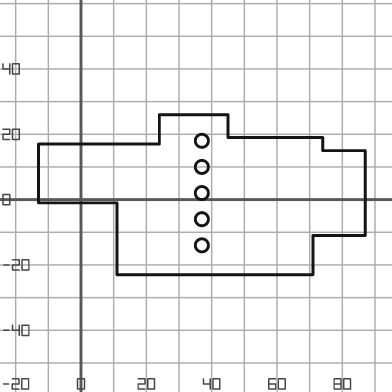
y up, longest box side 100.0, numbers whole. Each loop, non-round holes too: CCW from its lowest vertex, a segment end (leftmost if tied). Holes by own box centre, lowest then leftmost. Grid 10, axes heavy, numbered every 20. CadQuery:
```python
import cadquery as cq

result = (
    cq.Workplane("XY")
    .moveTo(11.0, -23.0)
    .lineTo(71.0, -23.0)
    .lineTo(71.0, -11.0)
    .lineTo(87.0, -11.0)
    .lineTo(87.0, 15.0)
    .lineTo(74.0, 15.0)
    .lineTo(74.0, 19.0)
    .lineTo(45.0, 19.0)
    .lineTo(45.0, 26.0)
    .lineTo(24.0, 26.0)
    .lineTo(24.0, 17.0)
    .lineTo(-13.0, 17.0)
    .lineTo(-13.0, -1.0)
    .lineTo(11.0, -1.0)
    .close()
    .moveTo(37.0, -14.0)
    .circle(2.0)
    .moveTo(37.0, -6.0)
    .circle(2.0)
    .moveTo(37.0, 2.0)
    .circle(2.0)
    .moveTo(37.0, 10.0)
    .circle(2.0)
    .moveTo(37.0, 18.0)
    .circle(2.0)
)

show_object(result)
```